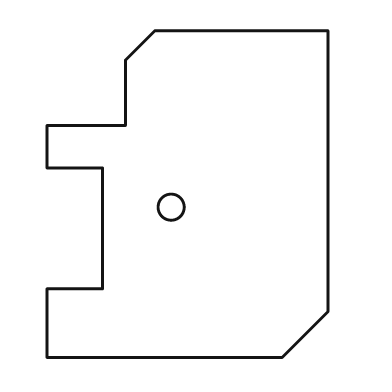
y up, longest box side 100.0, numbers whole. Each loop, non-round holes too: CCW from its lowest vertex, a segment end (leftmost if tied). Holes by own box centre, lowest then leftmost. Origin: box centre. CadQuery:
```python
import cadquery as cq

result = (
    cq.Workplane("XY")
    .moveTo(-43.0, -50.0)
    .lineTo(29.0, -50.0)
    .lineTo(43.0, -36.0)
    .lineTo(43.0, 50.0)
    .lineTo(-10.0, 50.0)
    .lineTo(-19.0, 41.0)
    .lineTo(-19.0, 21.0)
    .lineTo(-43.0, 21.0)
    .lineTo(-43.0, 8.0)
    .lineTo(-26.0, 8.0)
    .lineTo(-26.0, -29.0)
    .lineTo(-43.0, -29.0)
    .close()
    .moveTo(-5.0, -4.0)
    .circle(4.0)
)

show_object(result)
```